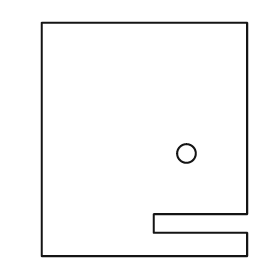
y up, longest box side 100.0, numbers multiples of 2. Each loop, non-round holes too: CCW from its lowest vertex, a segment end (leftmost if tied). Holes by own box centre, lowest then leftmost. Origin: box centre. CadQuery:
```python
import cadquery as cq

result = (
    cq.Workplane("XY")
    .moveTo(-44.0, -50.0)
    .lineTo(44.0, -50.0)
    .lineTo(44.0, -40.0)
    .lineTo(4.0, -40.0)
    .lineTo(4.0, -32.0)
    .lineTo(44.0, -32.0)
    .lineTo(44.0, 50.0)
    .lineTo(-44.0, 50.0)
    .close()
    .moveTo(18.0, -6.0)
    .circle(4.0)
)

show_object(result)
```